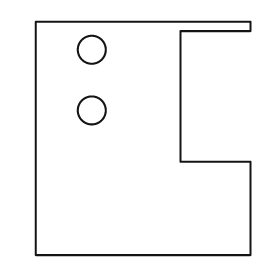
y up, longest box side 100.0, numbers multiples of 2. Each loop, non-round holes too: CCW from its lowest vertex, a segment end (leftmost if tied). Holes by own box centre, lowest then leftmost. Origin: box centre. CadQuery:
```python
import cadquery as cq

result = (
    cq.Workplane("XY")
    .moveTo(-46.0, -50.0)
    .lineTo(46.0, -50.0)
    .lineTo(46.0, -10.0)
    .lineTo(16.0, -10.0)
    .lineTo(16.0, 46.0)
    .lineTo(46.0, 46.0)
    .lineTo(46.0, 50.0)
    .lineTo(-46.0, 50.0)
    .close()
    .moveTo(-22.0, 12.0)
    .circle(6.0)
    .moveTo(-22.0, 38.0)
    .circle(6.0)
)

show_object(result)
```